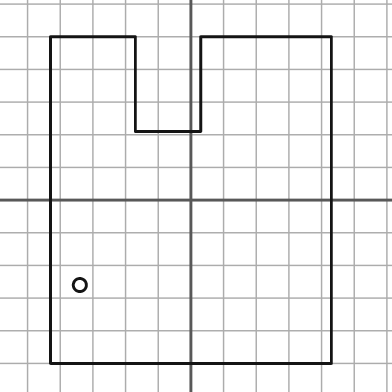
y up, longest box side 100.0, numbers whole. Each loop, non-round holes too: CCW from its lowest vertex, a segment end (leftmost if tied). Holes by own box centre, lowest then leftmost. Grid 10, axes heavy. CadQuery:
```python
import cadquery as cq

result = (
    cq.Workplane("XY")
    .moveTo(-43.0, -50.0)
    .lineTo(43.0, -50.0)
    .lineTo(43.0, 50.0)
    .lineTo(3.0, 50.0)
    .lineTo(3.0, 21.0)
    .lineTo(-17.0, 21.0)
    .lineTo(-17.0, 50.0)
    .lineTo(-43.0, 50.0)
    .close()
    .moveTo(-34.0, -26.0)
    .circle(2.0)
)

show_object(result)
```